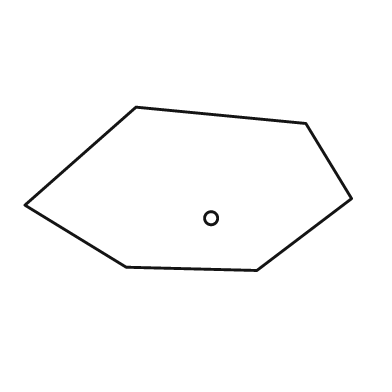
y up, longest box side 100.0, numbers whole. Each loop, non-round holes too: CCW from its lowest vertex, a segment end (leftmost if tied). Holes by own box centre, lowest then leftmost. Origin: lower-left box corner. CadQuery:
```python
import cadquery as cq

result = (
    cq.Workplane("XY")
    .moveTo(71.0, 0.0)
    .lineTo(100.0, 22.0)
    .lineTo(86.0, 45.0)
    .lineTo(34.0, 50.0)
    .lineTo(0.0, 20.0)
    .lineTo(31.0, 1.0)
    .close()
    .moveTo(57.0, 16.0)
    .circle(2.0)
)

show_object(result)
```